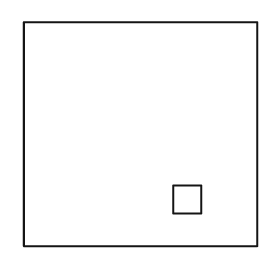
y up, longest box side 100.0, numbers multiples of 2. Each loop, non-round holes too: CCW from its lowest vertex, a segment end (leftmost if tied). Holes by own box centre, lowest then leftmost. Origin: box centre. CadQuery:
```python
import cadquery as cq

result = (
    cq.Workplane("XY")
    .moveTo(-50.0, -48.0)
    .lineTo(50.0, -48.0)
    .lineTo(50.0, 48.0)
    .lineTo(-50.0, 48.0)
    .close()
    .moveTo(14.0, -34.0)
    .lineTo(26.0, -34.0)
    .lineTo(26.0, -22.0)
    .lineTo(14.0, -22.0)
    .close()
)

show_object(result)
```